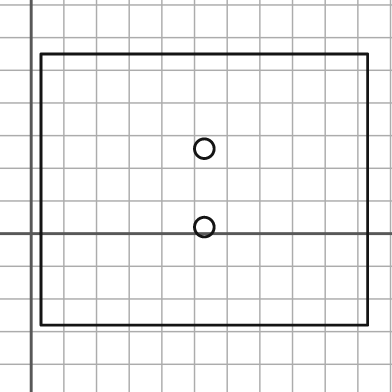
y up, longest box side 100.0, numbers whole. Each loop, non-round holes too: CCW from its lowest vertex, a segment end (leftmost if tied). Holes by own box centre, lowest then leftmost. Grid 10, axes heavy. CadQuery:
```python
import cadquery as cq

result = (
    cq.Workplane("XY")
    .moveTo(3.0, -28.0)
    .lineTo(103.0, -28.0)
    .lineTo(103.0, 55.0)
    .lineTo(3.0, 55.0)
    .close()
    .moveTo(53.0, 2.0)
    .circle(3.0)
    .moveTo(53.0, 26.0)
    .circle(3.0)
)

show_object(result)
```